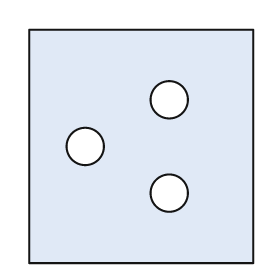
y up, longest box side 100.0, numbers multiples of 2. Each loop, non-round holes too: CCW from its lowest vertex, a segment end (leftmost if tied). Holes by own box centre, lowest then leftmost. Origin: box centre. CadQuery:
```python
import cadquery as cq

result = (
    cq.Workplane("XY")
    .moveTo(-48.0, -50.0)
    .lineTo(48.0, -50.0)
    .lineTo(48.0, 50.0)
    .lineTo(-48.0, 50.0)
    .close()
    .moveTo(12.0, -20.0)
    .circle(8.0)
    .moveTo(-24.0, 0.0)
    .circle(8.0)
    .moveTo(12.0, 20.0)
    .circle(8.0)
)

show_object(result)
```